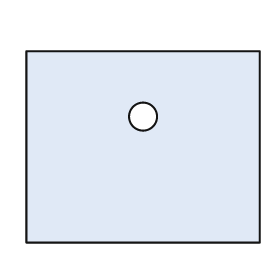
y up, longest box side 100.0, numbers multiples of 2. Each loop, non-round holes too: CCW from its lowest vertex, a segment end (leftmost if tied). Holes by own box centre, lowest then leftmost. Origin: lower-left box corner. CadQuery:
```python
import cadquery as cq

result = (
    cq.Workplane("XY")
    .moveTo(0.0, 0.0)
    .lineTo(100.0, 0.0)
    .lineTo(100.0, 82.0)
    .lineTo(0.0, 82.0)
    .close()
    .moveTo(50.0, 54.0)
    .circle(6.0)
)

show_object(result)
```